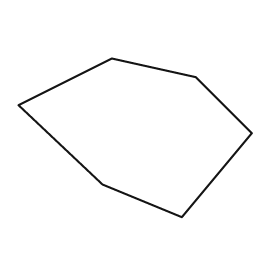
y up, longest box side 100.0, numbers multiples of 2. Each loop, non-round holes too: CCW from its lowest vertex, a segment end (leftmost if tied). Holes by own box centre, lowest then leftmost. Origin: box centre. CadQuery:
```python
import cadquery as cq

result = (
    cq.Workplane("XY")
    .moveTo(20.0, -34.0)
    .lineTo(50.0, 2.0)
    .lineTo(26.0, 26.0)
    .lineTo(-10.0, 34.0)
    .lineTo(-50.0, 14.0)
    .lineTo(-14.0, -20.0)
    .close()
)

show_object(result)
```